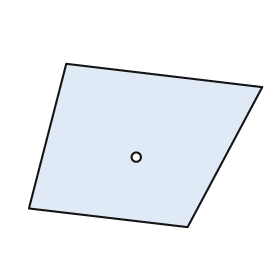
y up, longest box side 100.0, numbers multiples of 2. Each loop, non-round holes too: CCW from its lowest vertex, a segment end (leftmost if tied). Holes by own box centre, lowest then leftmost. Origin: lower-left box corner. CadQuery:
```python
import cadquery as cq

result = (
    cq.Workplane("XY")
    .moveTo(68.0, 0.0)
    .lineTo(100.0, 60.0)
    .lineTo(16.0, 70.0)
    .lineTo(0.0, 8.0)
    .close()
    .moveTo(46.0, 30.0)
    .circle(2.0)
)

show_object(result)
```